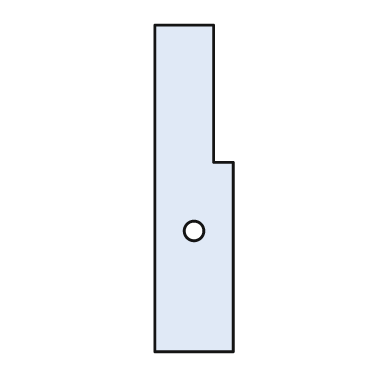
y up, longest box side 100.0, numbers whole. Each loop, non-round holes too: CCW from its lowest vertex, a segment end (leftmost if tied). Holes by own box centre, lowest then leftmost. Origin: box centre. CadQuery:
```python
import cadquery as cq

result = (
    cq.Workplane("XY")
    .moveTo(-12.0, -50.0)
    .lineTo(12.0, -50.0)
    .lineTo(12.0, 8.0)
    .lineTo(6.0, 8.0)
    .lineTo(6.0, 50.0)
    .lineTo(-12.0, 50.0)
    .close()
    .moveTo(0.0, -13.0)
    .circle(3.0)
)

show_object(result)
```